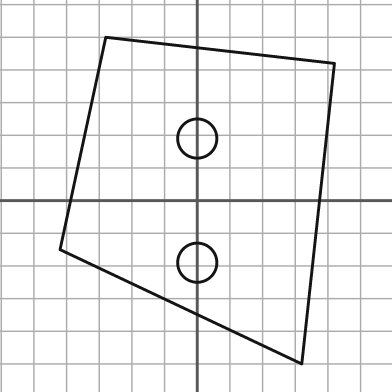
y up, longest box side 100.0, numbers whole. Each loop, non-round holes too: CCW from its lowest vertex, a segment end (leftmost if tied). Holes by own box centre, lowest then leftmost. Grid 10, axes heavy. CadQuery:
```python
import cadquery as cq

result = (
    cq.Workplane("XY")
    .moveTo(32.0, -50.0)
    .lineTo(42.0, 42.0)
    .lineTo(-28.0, 50.0)
    .lineTo(-42.0, -15.0)
    .close()
    .moveTo(0.0, -19.0)
    .circle(6.0)
    .moveTo(0.0, 19.0)
    .circle(6.0)
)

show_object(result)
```